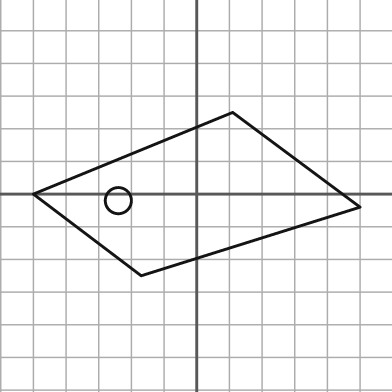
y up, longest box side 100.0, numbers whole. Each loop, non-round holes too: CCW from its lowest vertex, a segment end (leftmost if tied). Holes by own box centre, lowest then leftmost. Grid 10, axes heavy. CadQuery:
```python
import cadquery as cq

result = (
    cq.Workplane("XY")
    .moveTo(-17.0, -25.0)
    .lineTo(50.0, -4.0)
    .lineTo(11.0, 25.0)
    .lineTo(-50.0, 0.0)
    .close()
    .moveTo(-24.0, -2.0)
    .circle(4.0)
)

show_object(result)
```